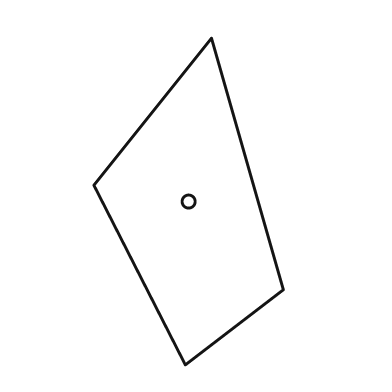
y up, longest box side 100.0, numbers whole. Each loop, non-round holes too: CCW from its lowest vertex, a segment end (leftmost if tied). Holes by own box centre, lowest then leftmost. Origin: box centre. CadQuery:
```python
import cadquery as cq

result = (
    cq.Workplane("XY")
    .moveTo(-1.0, -50.0)
    .lineTo(29.0, -27.0)
    .lineTo(7.0, 50.0)
    .lineTo(-29.0, 5.0)
    .close()
    .moveTo(0.0, 0.0)
    .circle(2.0)
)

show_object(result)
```